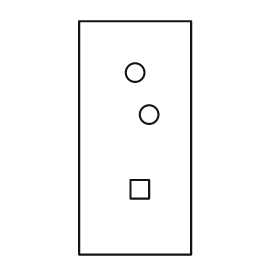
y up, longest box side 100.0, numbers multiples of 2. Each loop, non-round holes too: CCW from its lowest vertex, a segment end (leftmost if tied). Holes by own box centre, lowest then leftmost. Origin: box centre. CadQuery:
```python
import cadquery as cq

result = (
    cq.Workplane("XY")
    .moveTo(-24.0, -50.0)
    .lineTo(24.0, -50.0)
    .lineTo(24.0, 50.0)
    .lineTo(-24.0, 50.0)
    .close()
    .moveTo(-2.0, -26.0)
    .lineTo(6.0, -26.0)
    .lineTo(6.0, -18.0)
    .lineTo(-2.0, -18.0)
    .close()
    .moveTo(6.0, 10.0)
    .circle(4.0)
    .moveTo(0.0, 28.0)
    .circle(4.0)
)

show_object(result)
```